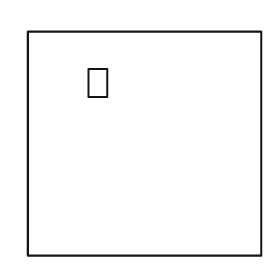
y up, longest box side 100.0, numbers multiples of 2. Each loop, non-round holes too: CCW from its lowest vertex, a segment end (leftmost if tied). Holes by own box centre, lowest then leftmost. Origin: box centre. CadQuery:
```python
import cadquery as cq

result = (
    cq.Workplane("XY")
    .moveTo(-50.0, -48.0)
    .lineTo(50.0, -48.0)
    .lineTo(50.0, 48.0)
    .lineTo(-50.0, 48.0)
    .close()
    .moveTo(-24.0, 20.0)
    .lineTo(-16.0, 20.0)
    .lineTo(-16.0, 32.0)
    .lineTo(-24.0, 32.0)
    .close()
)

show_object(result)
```